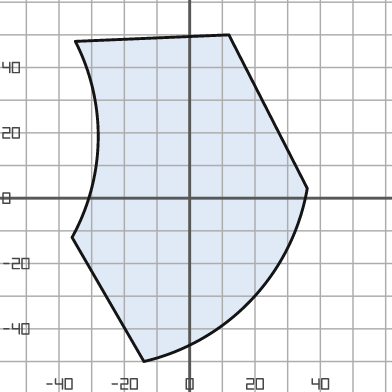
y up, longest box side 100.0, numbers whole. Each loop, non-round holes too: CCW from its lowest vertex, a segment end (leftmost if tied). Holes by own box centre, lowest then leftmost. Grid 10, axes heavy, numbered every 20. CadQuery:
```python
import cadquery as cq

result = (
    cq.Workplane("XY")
    .moveTo(-14.0, -50.0)
    .threePointArc((19.0, -31.0), (36.0, 3.0))
    .lineTo(12.0, 50.0)
    .lineTo(-35.0, 48.0)
    .threePointArc((-28.0, 18.0), (-36.0, -12.0))
    .close()
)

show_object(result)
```